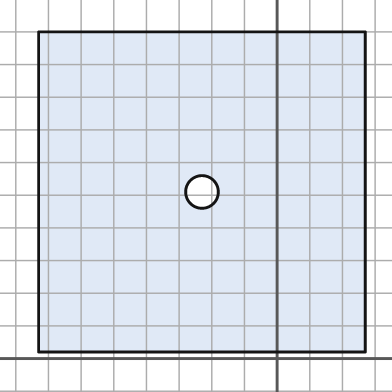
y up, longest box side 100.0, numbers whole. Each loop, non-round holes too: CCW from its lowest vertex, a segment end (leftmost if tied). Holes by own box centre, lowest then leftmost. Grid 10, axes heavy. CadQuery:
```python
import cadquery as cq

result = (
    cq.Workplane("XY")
    .moveTo(-73.0, 2.0)
    .lineTo(27.0, 2.0)
    .lineTo(27.0, 100.0)
    .lineTo(-73.0, 100.0)
    .close()
    .moveTo(-23.0, 51.0)
    .circle(5.0)
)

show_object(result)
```